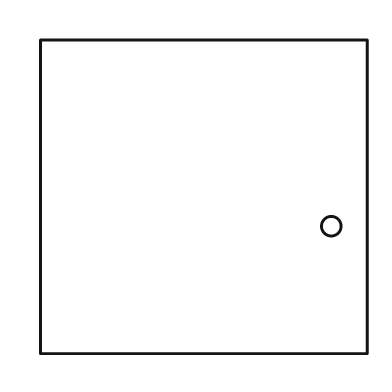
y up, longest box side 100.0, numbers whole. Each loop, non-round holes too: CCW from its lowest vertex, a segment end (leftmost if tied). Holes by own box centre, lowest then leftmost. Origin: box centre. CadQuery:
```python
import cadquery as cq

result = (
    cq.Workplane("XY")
    .moveTo(-50.0, -48.0)
    .lineTo(50.0, -48.0)
    .lineTo(50.0, 48.0)
    .lineTo(-50.0, 48.0)
    .close()
    .moveTo(39.0, -9.0)
    .circle(3.0)
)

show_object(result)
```